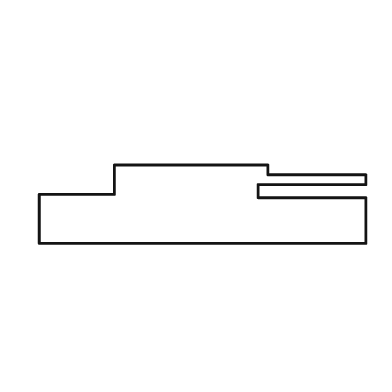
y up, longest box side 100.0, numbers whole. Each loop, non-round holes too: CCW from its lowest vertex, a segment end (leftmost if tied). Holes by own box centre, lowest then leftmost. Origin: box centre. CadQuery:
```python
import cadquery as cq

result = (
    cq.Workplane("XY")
    .moveTo(-50.0, -12.0)
    .lineTo(50.0, -12.0)
    .lineTo(50.0, 2.0)
    .lineTo(17.0, 2.0)
    .lineTo(17.0, 6.0)
    .lineTo(50.0, 6.0)
    .lineTo(50.0, 9.0)
    .lineTo(20.0, 9.0)
    .lineTo(20.0, 12.0)
    .lineTo(-27.0, 12.0)
    .lineTo(-27.0, 3.0)
    .lineTo(-50.0, 3.0)
    .close()
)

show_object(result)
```